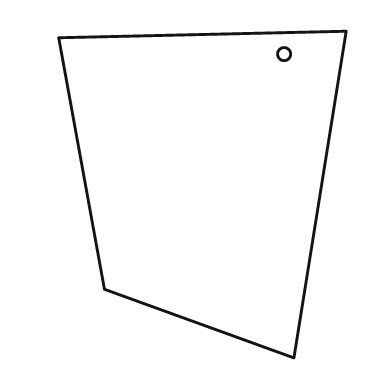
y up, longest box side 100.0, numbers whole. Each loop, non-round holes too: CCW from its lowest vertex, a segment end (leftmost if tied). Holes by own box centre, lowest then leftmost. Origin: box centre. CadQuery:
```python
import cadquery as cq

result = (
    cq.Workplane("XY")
    .moveTo(28.0, -50.0)
    .lineTo(44.0, 50.0)
    .lineTo(-44.0, 48.0)
    .lineTo(-30.0, -29.0)
    .close()
    .moveTo(25.0, 43.0)
    .circle(2.0)
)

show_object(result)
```